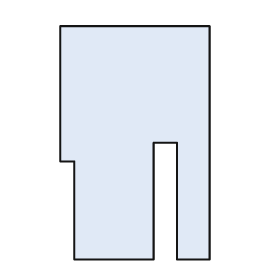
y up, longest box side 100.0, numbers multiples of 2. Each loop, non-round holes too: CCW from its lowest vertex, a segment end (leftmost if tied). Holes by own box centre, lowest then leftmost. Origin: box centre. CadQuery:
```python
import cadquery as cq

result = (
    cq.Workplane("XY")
    .moveTo(-26.0, -50.0)
    .lineTo(8.0, -50.0)
    .lineTo(8.0, 0.0)
    .lineTo(18.0, 0.0)
    .lineTo(18.0, -50.0)
    .lineTo(32.0, -50.0)
    .lineTo(32.0, 50.0)
    .lineTo(-32.0, 50.0)
    .lineTo(-32.0, -8.0)
    .lineTo(-26.0, -8.0)
    .close()
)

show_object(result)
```